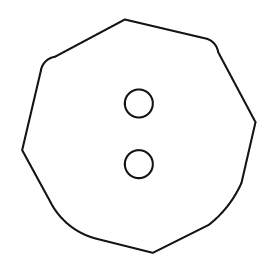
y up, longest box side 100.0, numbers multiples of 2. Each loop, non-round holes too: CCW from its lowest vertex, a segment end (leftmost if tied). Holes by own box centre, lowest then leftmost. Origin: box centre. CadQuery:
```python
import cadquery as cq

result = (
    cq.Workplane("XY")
    .moveTo(6.0, -50.0)
    .lineTo(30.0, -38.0)
    .threePointArc((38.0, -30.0), (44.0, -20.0))
    .lineTo(50.0, 6.0)
    .lineTo(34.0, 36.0)
    .threePointArc((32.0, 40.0), (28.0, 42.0))
    .lineTo(-6.0, 50.0)
    .lineTo(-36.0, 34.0)
    .threePointArc((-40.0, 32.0), (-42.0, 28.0))
    .lineTo(-50.0, -6.0)
    .lineTo(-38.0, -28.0)
    .threePointArc((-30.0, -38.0), (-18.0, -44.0))
    .close()
    .moveTo(0.0, -12.0)
    .circle(6.0)
    .moveTo(0.0, 14.0)
    .circle(6.0)
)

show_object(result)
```